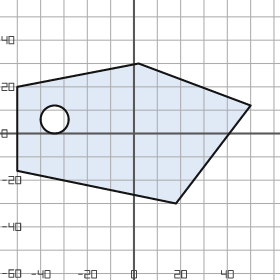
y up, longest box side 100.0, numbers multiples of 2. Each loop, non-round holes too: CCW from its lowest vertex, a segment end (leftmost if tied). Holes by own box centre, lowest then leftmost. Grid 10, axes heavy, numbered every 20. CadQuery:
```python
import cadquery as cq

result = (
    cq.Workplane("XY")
    .moveTo(18.0, -30.0)
    .lineTo(50.0, 12.0)
    .lineTo(2.0, 30.0)
    .lineTo(-50.0, 20.0)
    .lineTo(-50.0, -16.0)
    .close()
    .moveTo(-34.0, 6.0)
    .circle(6.0)
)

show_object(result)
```